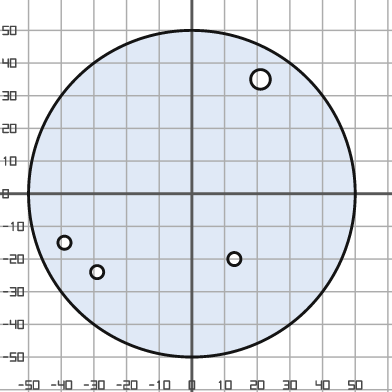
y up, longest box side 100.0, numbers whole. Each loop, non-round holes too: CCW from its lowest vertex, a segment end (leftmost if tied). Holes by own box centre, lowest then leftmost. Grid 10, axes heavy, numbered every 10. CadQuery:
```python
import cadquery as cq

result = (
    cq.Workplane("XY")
    .moveTo(0.0, 0.0)
    .circle(50.0)
    .moveTo(-29.0, -24.0)
    .circle(2.0)
    .moveTo(13.0, -20.0)
    .circle(2.0)
    .moveTo(-39.0, -15.0)
    .circle(2.0)
    .moveTo(21.0, 35.0)
    .circle(3.0)
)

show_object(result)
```